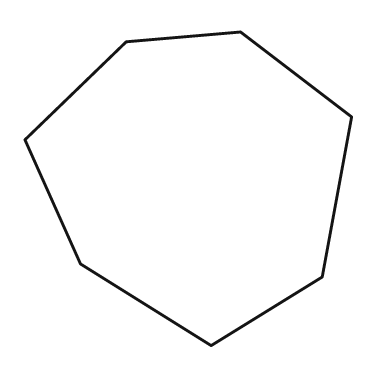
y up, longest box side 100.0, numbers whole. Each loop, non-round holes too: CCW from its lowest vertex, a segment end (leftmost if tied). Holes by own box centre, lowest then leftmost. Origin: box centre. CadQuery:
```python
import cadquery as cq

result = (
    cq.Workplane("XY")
    .moveTo(7.0, -48.0)
    .lineTo(41.0, -27.0)
    .lineTo(50.0, 22.0)
    .lineTo(16.0, 48.0)
    .lineTo(-19.0, 45.0)
    .lineTo(-50.0, 15.0)
    .lineTo(-33.0, -23.0)
    .close()
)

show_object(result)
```